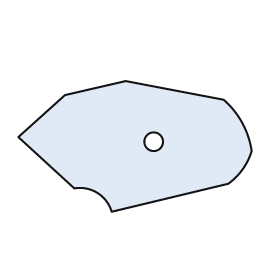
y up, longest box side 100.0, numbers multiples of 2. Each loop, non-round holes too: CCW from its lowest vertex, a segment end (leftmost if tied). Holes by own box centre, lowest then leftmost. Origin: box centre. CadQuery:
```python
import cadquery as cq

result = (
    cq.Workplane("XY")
    .moveTo(-10.0, -28.0)
    .lineTo(40.0, -16.0)
    .threePointArc((46.0, -10.0), (50.0, -2.0))
    .threePointArc((46.0, 10.0), (38.0, 20.0))
    .lineTo(-4.0, 28.0)
    .lineTo(-30.0, 22.0)
    .lineTo(-50.0, 4.0)
    .lineTo(-26.0, -18.0)
    .threePointArc((-16.0, -20.0), (-10.0, -28.0))
    .close()
    .moveTo(8.0, 2.0)
    .circle(4.0)
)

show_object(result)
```